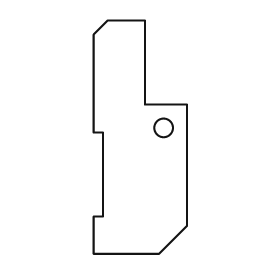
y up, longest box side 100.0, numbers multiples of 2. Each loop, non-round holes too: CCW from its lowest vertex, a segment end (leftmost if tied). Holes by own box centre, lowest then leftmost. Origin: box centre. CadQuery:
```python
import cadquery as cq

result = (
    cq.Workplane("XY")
    .moveTo(-20.0, -50.0)
    .lineTo(8.0, -50.0)
    .lineTo(20.0, -38.0)
    .lineTo(20.0, 14.0)
    .lineTo(2.0, 14.0)
    .lineTo(2.0, 50.0)
    .lineTo(-14.0, 50.0)
    .lineTo(-20.0, 44.0)
    .lineTo(-20.0, 2.0)
    .lineTo(-16.0, 2.0)
    .lineTo(-16.0, -34.0)
    .lineTo(-20.0, -34.0)
    .close()
    .moveTo(10.0, 4.0)
    .circle(4.0)
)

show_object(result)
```